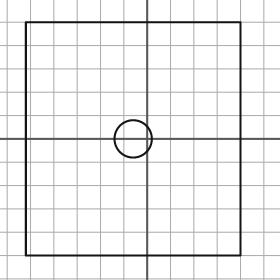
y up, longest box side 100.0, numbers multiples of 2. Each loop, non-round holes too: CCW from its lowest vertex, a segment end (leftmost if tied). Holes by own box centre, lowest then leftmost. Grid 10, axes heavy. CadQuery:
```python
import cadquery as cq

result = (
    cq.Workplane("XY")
    .moveTo(-52.0, -50.0)
    .lineTo(40.0, -50.0)
    .lineTo(40.0, 50.0)
    .lineTo(-52.0, 50.0)
    .close()
    .moveTo(-6.0, 0.0)
    .circle(8.0)
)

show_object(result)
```